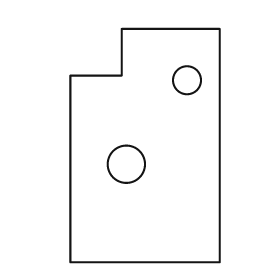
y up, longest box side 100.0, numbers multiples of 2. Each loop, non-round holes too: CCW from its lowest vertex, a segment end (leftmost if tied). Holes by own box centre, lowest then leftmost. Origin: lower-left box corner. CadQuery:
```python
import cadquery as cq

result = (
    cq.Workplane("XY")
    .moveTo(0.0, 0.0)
    .lineTo(64.0, 0.0)
    .lineTo(64.0, 100.0)
    .lineTo(22.0, 100.0)
    .lineTo(22.0, 80.0)
    .lineTo(0.0, 80.0)
    .close()
    .moveTo(24.0, 42.0)
    .circle(8.0)
    .moveTo(50.0, 78.0)
    .circle(6.0)
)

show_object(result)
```